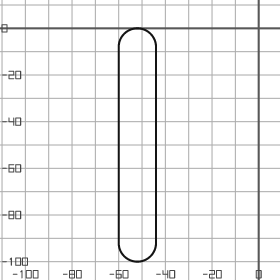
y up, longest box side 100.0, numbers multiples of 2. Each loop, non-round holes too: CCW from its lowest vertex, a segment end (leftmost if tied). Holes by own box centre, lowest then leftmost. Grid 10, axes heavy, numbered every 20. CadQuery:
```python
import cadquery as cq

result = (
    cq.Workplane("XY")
    .moveTo(-60.0, -92.0)
    .threePointArc((-52.0, -100.0), (-44.0, -92.0))
    .lineTo(-44.0, -8.0)
    .threePointArc((-52.0, 0.0), (-60.0, -8.0))
    .close()
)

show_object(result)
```